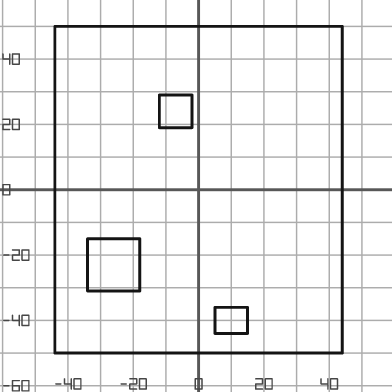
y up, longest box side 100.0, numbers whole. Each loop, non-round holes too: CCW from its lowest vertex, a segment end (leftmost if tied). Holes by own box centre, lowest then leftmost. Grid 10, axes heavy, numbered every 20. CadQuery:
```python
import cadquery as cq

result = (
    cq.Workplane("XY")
    .moveTo(-44.0, -50.0)
    .lineTo(44.0, -50.0)
    .lineTo(44.0, 50.0)
    .lineTo(-44.0, 50.0)
    .close()
    .moveTo(5.0, -44.0)
    .lineTo(15.0, -44.0)
    .lineTo(15.0, -36.0)
    .lineTo(5.0, -36.0)
    .close()
    .moveTo(-34.0, -31.0)
    .lineTo(-18.0, -31.0)
    .lineTo(-18.0, -15.0)
    .lineTo(-34.0, -15.0)
    .close()
    .moveTo(-12.0, 19.0)
    .lineTo(-2.0, 19.0)
    .lineTo(-2.0, 29.0)
    .lineTo(-12.0, 29.0)
    .close()
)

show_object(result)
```